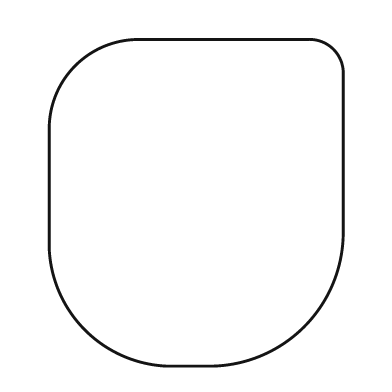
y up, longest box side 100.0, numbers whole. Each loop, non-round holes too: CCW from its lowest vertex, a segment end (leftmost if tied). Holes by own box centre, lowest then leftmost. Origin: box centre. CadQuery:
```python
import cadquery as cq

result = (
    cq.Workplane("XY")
    .moveTo(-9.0, -50.0)
    .lineTo(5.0, -50.0)
    .threePointArc((33.0, -38.0), (45.0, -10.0))
    .lineTo(45.0, 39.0)
    .threePointArc((42.0, 47.0), (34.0, 50.0))
    .lineTo(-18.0, 50.0)
    .threePointArc((-37.0, 42.0), (-45.0, 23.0))
    .lineTo(-45.0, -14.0)
    .threePointArc((-34.0, -39.0), (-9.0, -50.0))
    .close()
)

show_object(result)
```